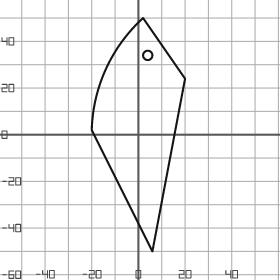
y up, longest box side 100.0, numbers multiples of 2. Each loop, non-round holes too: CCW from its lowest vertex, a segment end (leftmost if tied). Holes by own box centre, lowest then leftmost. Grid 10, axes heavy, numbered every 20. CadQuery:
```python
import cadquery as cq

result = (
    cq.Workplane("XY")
    .moveTo(6.0, -50.0)
    .lineTo(20.0, 24.0)
    .lineTo(2.0, 50.0)
    .threePointArc((-14.0, 28.0), (-20.0, 2.0))
    .close()
    .moveTo(4.0, 34.0)
    .circle(2.0)
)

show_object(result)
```